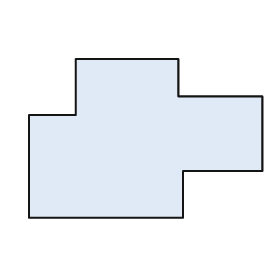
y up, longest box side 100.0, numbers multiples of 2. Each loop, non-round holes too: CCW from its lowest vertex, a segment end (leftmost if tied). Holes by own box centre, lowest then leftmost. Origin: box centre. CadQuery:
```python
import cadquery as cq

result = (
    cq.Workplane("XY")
    .moveTo(-50.0, -34.0)
    .lineTo(16.0, -34.0)
    .lineTo(16.0, -14.0)
    .lineTo(50.0, -14.0)
    .lineTo(50.0, 18.0)
    .lineTo(14.0, 18.0)
    .lineTo(14.0, 34.0)
    .lineTo(-30.0, 34.0)
    .lineTo(-30.0, 10.0)
    .lineTo(-50.0, 10.0)
    .close()
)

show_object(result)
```